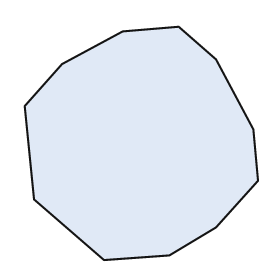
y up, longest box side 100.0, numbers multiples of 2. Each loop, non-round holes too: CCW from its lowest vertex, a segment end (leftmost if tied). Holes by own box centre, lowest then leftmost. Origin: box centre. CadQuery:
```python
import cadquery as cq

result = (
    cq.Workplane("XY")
    .moveTo(-16.0, -50.0)
    .lineTo(12.0, -48.0)
    .lineTo(32.0, -36.0)
    .lineTo(50.0, -16.0)
    .lineTo(48.0, 6.0)
    .lineTo(32.0, 36.0)
    .lineTo(16.0, 50.0)
    .lineTo(-8.0, 48.0)
    .lineTo(-34.0, 34.0)
    .lineTo(-50.0, 16.0)
    .lineTo(-46.0, -24.0)
    .close()
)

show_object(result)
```